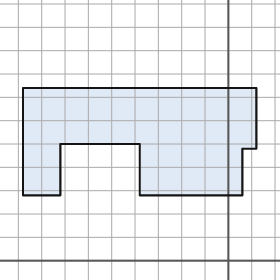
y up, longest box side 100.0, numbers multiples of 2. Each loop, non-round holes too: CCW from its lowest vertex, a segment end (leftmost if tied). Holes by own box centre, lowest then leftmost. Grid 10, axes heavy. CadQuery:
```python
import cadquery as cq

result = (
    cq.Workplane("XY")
    .moveTo(-88.0, 28.0)
    .lineTo(-72.0, 28.0)
    .lineTo(-72.0, 50.0)
    .lineTo(-38.0, 50.0)
    .lineTo(-38.0, 28.0)
    .lineTo(6.0, 28.0)
    .lineTo(6.0, 48.0)
    .lineTo(12.0, 48.0)
    .lineTo(12.0, 74.0)
    .lineTo(-88.0, 74.0)
    .close()
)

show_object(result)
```